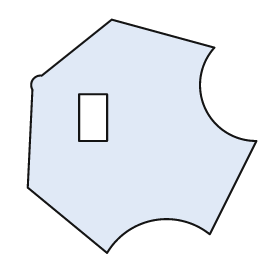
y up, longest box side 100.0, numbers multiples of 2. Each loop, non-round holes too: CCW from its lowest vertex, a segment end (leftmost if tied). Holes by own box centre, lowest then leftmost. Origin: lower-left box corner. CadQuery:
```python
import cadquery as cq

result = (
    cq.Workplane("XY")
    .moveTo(34.0, 0.0)
    .threePointArc((54.0, 14.0), (78.0, 8.0))
    .lineTo(98.0, 48.0)
    .threePointArc((76.0, 62.0), (80.0, 88.0))
    .lineTo(36.0, 100.0)
    .lineTo(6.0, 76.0)
    .threePointArc((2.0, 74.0), (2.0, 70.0))
    .lineTo(0.0, 28.0)
    .close()
    .moveTo(22.0, 48.0)
    .lineTo(34.0, 48.0)
    .lineTo(34.0, 68.0)
    .lineTo(22.0, 68.0)
    .close()
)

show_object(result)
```